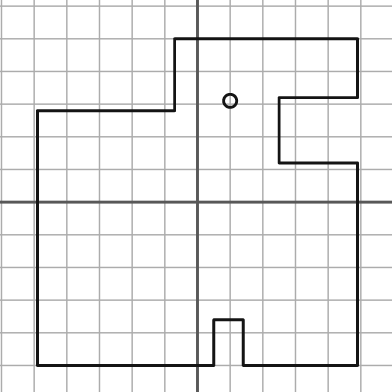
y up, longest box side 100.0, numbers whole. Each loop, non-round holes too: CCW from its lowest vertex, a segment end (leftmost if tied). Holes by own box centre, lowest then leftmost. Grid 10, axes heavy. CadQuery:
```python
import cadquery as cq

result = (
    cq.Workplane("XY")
    .moveTo(-49.0, -50.0)
    .lineTo(5.0, -50.0)
    .lineTo(5.0, -36.0)
    .lineTo(14.0, -36.0)
    .lineTo(14.0, -50.0)
    .lineTo(49.0, -50.0)
    .lineTo(49.0, 12.0)
    .lineTo(25.0, 12.0)
    .lineTo(25.0, 32.0)
    .lineTo(49.0, 32.0)
    .lineTo(49.0, 50.0)
    .lineTo(-7.0, 50.0)
    .lineTo(-7.0, 28.0)
    .lineTo(-49.0, 28.0)
    .close()
    .moveTo(10.0, 31.0)
    .circle(2.0)
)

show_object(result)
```